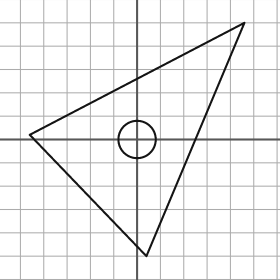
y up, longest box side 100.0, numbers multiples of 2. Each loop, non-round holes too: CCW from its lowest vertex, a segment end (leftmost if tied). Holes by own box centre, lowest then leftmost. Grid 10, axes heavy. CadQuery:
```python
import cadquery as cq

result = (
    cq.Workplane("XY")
    .moveTo(4.0, -50.0)
    .lineTo(46.0, 50.0)
    .lineTo(-46.0, 2.0)
    .close()
    .moveTo(0.0, 0.0)
    .circle(8.0)
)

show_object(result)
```